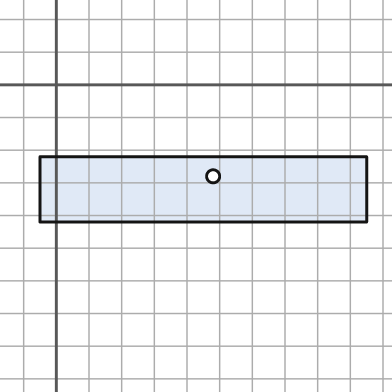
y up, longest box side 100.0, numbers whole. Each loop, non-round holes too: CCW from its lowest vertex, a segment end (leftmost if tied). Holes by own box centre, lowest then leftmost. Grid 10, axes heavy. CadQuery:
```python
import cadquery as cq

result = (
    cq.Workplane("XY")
    .moveTo(-5.0, -42.0)
    .lineTo(95.0, -42.0)
    .lineTo(95.0, -22.0)
    .lineTo(-5.0, -22.0)
    .close()
    .moveTo(48.0, -28.0)
    .circle(2.0)
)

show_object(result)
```